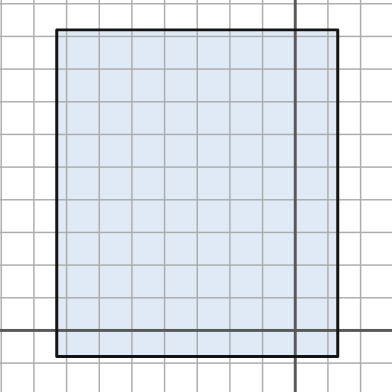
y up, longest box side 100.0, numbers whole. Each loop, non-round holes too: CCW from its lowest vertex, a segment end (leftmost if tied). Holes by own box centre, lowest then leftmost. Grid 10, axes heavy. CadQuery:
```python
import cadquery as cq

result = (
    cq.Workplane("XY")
    .moveTo(-73.0, -8.0)
    .lineTo(13.0, -8.0)
    .lineTo(13.0, 92.0)
    .lineTo(-73.0, 92.0)
    .close()
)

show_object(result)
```